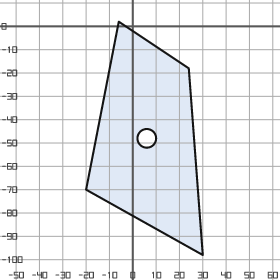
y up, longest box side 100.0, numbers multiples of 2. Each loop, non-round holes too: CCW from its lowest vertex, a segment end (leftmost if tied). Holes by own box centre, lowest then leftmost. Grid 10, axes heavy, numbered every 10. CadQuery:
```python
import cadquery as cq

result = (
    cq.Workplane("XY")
    .moveTo(30.0, -98.0)
    .lineTo(24.0, -18.0)
    .lineTo(-6.0, 2.0)
    .lineTo(-20.0, -70.0)
    .close()
    .moveTo(6.0, -48.0)
    .circle(4.0)
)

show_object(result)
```